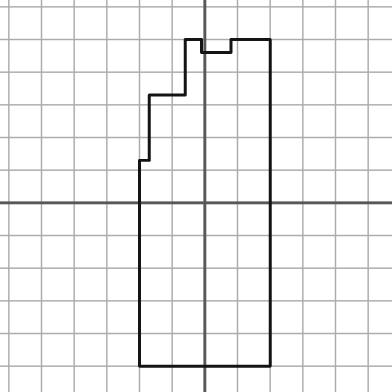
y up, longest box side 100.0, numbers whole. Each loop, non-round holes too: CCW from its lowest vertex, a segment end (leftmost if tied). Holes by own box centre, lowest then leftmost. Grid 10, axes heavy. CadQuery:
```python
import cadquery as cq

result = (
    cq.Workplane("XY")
    .moveTo(-20.0, -50.0)
    .lineTo(20.0, -50.0)
    .lineTo(20.0, 50.0)
    .lineTo(8.0, 50.0)
    .lineTo(8.0, 46.0)
    .lineTo(-1.0, 46.0)
    .lineTo(-1.0, 50.0)
    .lineTo(-6.0, 50.0)
    .lineTo(-6.0, 33.0)
    .lineTo(-17.0, 33.0)
    .lineTo(-17.0, 13.0)
    .lineTo(-20.0, 13.0)
    .close()
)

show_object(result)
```